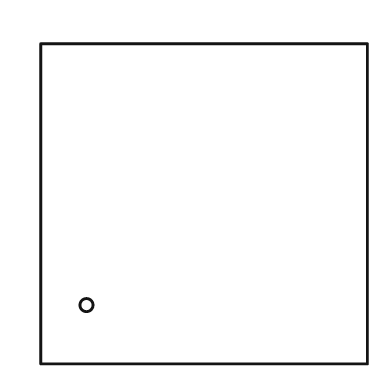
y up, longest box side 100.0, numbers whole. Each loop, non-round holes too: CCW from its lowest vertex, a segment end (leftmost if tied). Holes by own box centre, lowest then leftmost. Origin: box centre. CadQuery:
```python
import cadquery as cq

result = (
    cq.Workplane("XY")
    .moveTo(-50.0, -49.0)
    .lineTo(50.0, -49.0)
    .lineTo(50.0, 49.0)
    .lineTo(-50.0, 49.0)
    .close()
    .moveTo(-36.0, -31.0)
    .circle(2.0)
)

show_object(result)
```